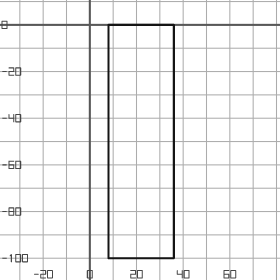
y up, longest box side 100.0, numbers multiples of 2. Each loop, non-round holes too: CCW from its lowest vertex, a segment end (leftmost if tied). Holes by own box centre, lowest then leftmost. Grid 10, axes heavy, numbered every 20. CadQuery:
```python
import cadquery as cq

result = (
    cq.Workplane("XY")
    .moveTo(8.0, -100.0)
    .lineTo(36.0, -100.0)
    .lineTo(36.0, 0.0)
    .lineTo(8.0, 0.0)
    .close()
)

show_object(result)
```